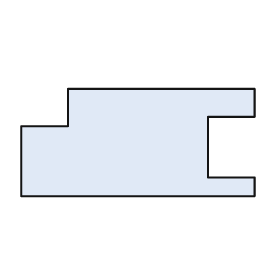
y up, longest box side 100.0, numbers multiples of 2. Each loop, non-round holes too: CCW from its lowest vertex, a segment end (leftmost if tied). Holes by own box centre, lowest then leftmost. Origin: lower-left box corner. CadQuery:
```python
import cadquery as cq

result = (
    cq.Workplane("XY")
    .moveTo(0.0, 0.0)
    .lineTo(100.0, 0.0)
    .lineTo(100.0, 8.0)
    .lineTo(80.0, 8.0)
    .lineTo(80.0, 34.0)
    .lineTo(100.0, 34.0)
    .lineTo(100.0, 46.0)
    .lineTo(20.0, 46.0)
    .lineTo(20.0, 30.0)
    .lineTo(0.0, 30.0)
    .close()
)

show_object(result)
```